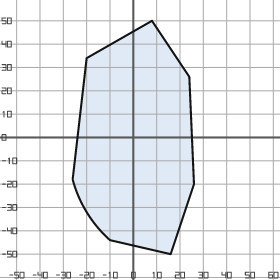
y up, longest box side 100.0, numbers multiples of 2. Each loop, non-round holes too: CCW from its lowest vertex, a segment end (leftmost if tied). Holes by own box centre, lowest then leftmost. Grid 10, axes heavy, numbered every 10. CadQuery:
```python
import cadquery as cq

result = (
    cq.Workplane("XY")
    .moveTo(16.0, -50.0)
    .lineTo(26.0, -20.0)
    .lineTo(24.0, 26.0)
    .lineTo(8.0, 50.0)
    .lineTo(-20.0, 34.0)
    .lineTo(-26.0, -18.0)
    .threePointArc((-20.0, -32.0), (-10.0, -44.0))
    .close()
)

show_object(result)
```